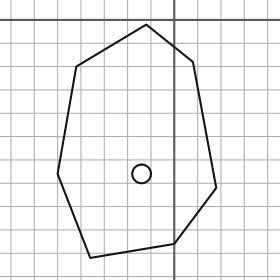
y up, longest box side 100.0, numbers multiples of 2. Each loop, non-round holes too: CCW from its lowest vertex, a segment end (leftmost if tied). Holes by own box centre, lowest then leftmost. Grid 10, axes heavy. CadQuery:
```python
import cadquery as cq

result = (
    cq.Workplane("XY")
    .moveTo(-36.0, -102.0)
    .lineTo(0.0, -96.0)
    .lineTo(18.0, -72.0)
    .lineTo(8.0, -18.0)
    .lineTo(-12.0, -2.0)
    .lineTo(-42.0, -20.0)
    .lineTo(-50.0, -66.0)
    .close()
    .moveTo(-14.0, -66.0)
    .circle(4.0)
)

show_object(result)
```